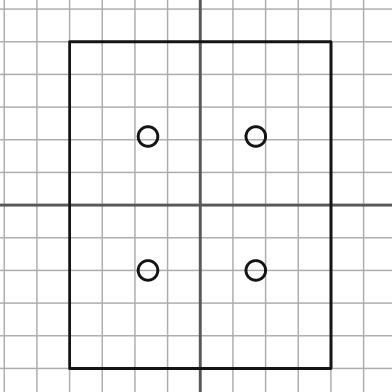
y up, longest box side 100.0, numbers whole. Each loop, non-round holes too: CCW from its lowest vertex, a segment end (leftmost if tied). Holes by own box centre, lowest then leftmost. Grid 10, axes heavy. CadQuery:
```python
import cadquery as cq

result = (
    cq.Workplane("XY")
    .moveTo(-40.0, -50.0)
    .lineTo(40.0, -50.0)
    .lineTo(40.0, 50.0)
    .lineTo(-40.0, 50.0)
    .close()
    .moveTo(-16.0, -20.0)
    .circle(3.0)
    .moveTo(17.0, -20.0)
    .circle(3.0)
    .moveTo(-16.0, 21.0)
    .circle(3.0)
    .moveTo(17.0, 21.0)
    .circle(3.0)
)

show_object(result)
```